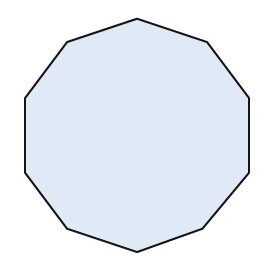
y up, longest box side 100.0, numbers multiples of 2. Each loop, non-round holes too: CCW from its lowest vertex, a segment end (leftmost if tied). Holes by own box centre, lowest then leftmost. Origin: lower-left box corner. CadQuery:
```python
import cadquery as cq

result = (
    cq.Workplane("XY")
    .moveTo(48.0, 0.0)
    .lineTo(76.0, 10.0)
    .lineTo(96.0, 34.0)
    .lineTo(96.0, 66.0)
    .lineTo(78.0, 90.0)
    .lineTo(48.0, 100.0)
    .lineTo(18.0, 90.0)
    .lineTo(0.0, 66.0)
    .lineTo(0.0, 34.0)
    .lineTo(18.0, 10.0)
    .close()
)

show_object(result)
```